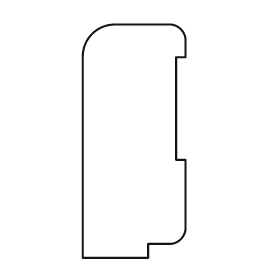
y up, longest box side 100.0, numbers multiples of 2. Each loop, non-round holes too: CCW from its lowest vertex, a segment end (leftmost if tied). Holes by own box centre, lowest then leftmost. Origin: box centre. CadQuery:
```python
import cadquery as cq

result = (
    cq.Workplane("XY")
    .moveTo(-22.0, -50.0)
    .lineTo(6.0, -50.0)
    .lineTo(6.0, -44.0)
    .lineTo(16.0, -44.0)
    .threePointArc((20.0, -42.0), (22.0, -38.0))
    .lineTo(22.0, -8.0)
    .lineTo(18.0, -8.0)
    .lineTo(18.0, 36.0)
    .lineTo(22.0, 36.0)
    .lineTo(22.0, 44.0)
    .threePointArc((20.0, 48.0), (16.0, 50.0))
    .lineTo(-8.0, 50.0)
    .threePointArc((-18.0, 46.0), (-22.0, 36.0))
    .close()
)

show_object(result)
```